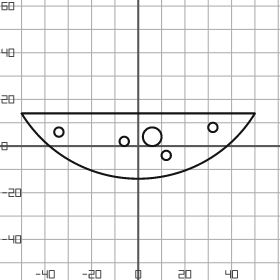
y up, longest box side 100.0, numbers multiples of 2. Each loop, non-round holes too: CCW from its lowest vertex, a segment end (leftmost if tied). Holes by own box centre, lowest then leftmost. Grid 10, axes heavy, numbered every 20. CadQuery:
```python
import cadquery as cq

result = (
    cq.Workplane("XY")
    .moveTo(-50.0, 14.0)
    .threePointArc((0.0, -14.0), (50.0, 14.0))
    .close()
    .moveTo(12.0, -4.0)
    .circle(2.0)
    .moveTo(-6.0, 2.0)
    .circle(2.0)
    .moveTo(6.0, 4.0)
    .circle(4.0)
    .moveTo(-34.0, 6.0)
    .circle(2.0)
    .moveTo(32.0, 8.0)
    .circle(2.0)
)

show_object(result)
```